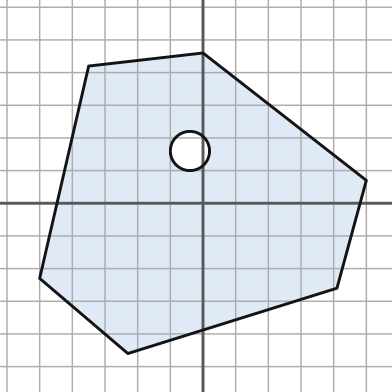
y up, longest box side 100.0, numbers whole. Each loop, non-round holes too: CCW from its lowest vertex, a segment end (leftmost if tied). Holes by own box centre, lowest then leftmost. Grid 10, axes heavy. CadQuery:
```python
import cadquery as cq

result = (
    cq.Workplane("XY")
    .moveTo(-23.0, -46.0)
    .lineTo(41.0, -26.0)
    .lineTo(50.0, 7.0)
    .lineTo(0.0, 46.0)
    .lineTo(-35.0, 42.0)
    .lineTo(-50.0, -23.0)
    .close()
    .moveTo(-4.0, 16.0)
    .circle(6.0)
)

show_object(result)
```